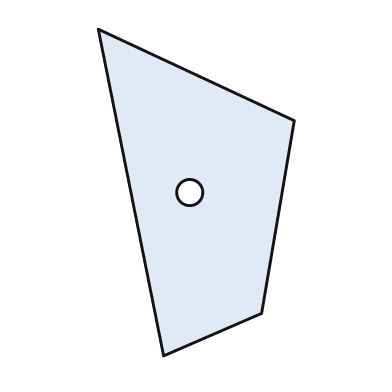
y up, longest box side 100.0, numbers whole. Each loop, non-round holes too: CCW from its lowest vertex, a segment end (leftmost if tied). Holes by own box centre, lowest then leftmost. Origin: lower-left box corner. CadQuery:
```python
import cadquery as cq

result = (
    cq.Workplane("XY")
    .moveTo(20.0, 0.0)
    .lineTo(50.0, 13.0)
    .lineTo(60.0, 72.0)
    .lineTo(0.0, 100.0)
    .close()
    .moveTo(28.0, 50.0)
    .circle(4.0)
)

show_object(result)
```